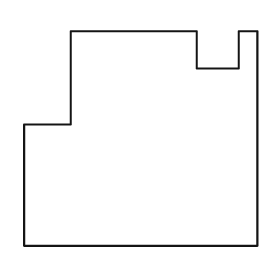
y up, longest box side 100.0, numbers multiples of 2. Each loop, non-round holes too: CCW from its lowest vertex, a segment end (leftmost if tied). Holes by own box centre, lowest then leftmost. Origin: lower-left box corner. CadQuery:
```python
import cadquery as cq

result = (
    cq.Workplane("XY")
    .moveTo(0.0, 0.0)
    .lineTo(100.0, 0.0)
    .lineTo(100.0, 92.0)
    .lineTo(92.0, 92.0)
    .lineTo(92.0, 76.0)
    .lineTo(74.0, 76.0)
    .lineTo(74.0, 92.0)
    .lineTo(20.0, 92.0)
    .lineTo(20.0, 52.0)
    .lineTo(0.0, 52.0)
    .close()
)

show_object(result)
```